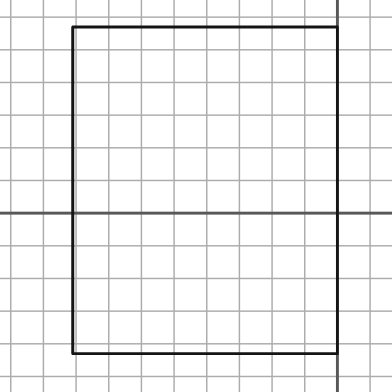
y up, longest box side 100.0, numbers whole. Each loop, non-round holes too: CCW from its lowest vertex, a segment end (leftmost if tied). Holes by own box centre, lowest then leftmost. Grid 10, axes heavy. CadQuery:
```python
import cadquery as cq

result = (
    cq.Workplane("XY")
    .moveTo(-81.0, -43.0)
    .lineTo(0.0, -43.0)
    .lineTo(0.0, 57.0)
    .lineTo(-81.0, 57.0)
    .close()
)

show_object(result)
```